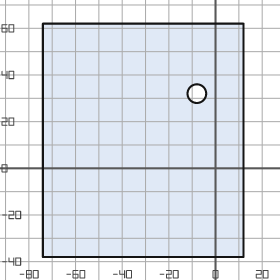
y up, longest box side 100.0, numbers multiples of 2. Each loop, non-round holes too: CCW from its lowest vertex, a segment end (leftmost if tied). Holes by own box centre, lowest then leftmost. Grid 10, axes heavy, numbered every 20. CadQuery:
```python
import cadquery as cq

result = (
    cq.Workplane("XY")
    .moveTo(-74.0, -38.0)
    .lineTo(12.0, -38.0)
    .lineTo(12.0, 62.0)
    .lineTo(-74.0, 62.0)
    .close()
    .moveTo(-8.0, 32.0)
    .circle(4.0)
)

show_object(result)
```